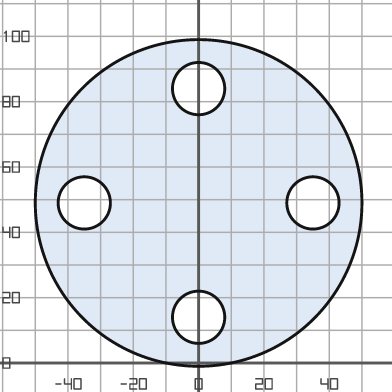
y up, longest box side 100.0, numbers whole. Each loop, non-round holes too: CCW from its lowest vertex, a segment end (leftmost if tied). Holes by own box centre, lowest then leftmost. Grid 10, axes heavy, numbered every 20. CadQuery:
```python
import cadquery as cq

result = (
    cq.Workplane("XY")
    .moveTo(0.0, 49.0)
    .circle(50.0)
    .moveTo(0.0, 14.0)
    .circle(8.0)
    .moveTo(-35.0, 49.0)
    .circle(8.0)
    .moveTo(35.0, 49.0)
    .circle(8.0)
    .moveTo(0.0, 84.0)
    .circle(8.0)
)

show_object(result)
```